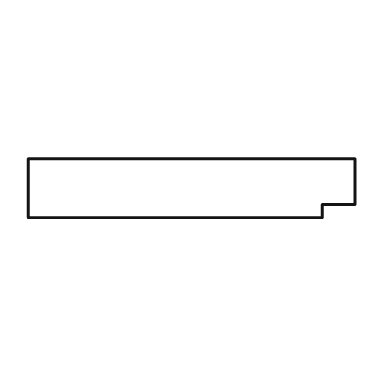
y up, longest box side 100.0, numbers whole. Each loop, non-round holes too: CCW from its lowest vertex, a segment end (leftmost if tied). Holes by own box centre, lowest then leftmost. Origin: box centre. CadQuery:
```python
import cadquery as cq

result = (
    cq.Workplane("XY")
    .moveTo(-50.0, -9.0)
    .lineTo(40.0, -9.0)
    .lineTo(40.0, -5.0)
    .lineTo(50.0, -5.0)
    .lineTo(50.0, 9.0)
    .lineTo(-50.0, 9.0)
    .close()
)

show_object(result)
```